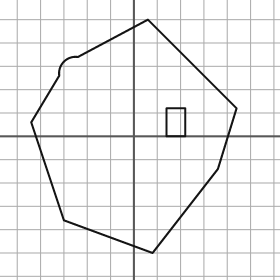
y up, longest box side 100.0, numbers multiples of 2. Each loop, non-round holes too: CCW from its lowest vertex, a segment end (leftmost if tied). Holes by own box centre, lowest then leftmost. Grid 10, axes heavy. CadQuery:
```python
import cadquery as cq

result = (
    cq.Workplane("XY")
    .moveTo(8.0, -50.0)
    .lineTo(36.0, -14.0)
    .lineTo(44.0, 12.0)
    .lineTo(6.0, 50.0)
    .lineTo(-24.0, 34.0)
    .threePointArc((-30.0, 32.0), (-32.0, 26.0))
    .lineTo(-44.0, 6.0)
    .lineTo(-30.0, -36.0)
    .close()
    .moveTo(14.0, 0.0)
    .lineTo(22.0, 0.0)
    .lineTo(22.0, 12.0)
    .lineTo(14.0, 12.0)
    .close()
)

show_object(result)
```